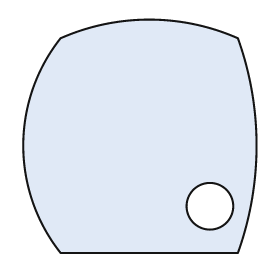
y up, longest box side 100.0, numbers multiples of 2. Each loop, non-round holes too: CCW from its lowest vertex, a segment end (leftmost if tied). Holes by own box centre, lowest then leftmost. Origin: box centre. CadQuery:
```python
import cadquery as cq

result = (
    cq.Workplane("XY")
    .moveTo(-34.0, -50.0)
    .lineTo(42.0, -50.0)
    .threePointArc((50.0, -4.0), (42.0, 42.0))
    .threePointArc((4.0, 50.0), (-34.0, 42.0))
    .threePointArc((-50.0, -4.0), (-34.0, -50.0))
    .close()
    .moveTo(30.0, -30.0)
    .circle(10.0)
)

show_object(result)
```